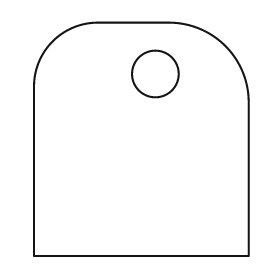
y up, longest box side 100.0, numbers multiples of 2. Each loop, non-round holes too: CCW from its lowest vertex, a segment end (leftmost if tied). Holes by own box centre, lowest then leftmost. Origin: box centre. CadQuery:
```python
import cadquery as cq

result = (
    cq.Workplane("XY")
    .moveTo(-46.0, -50.0)
    .lineTo(46.0, -50.0)
    .lineTo(46.0, 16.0)
    .threePointArc((36.0, 40.0), (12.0, 50.0))
    .lineTo(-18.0, 50.0)
    .threePointArc((-38.0, 42.0), (-46.0, 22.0))
    .close()
    .moveTo(6.0, 28.0)
    .circle(10.0)
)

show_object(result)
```